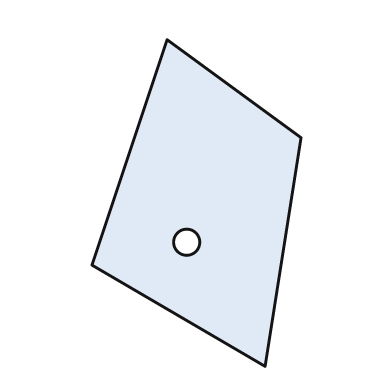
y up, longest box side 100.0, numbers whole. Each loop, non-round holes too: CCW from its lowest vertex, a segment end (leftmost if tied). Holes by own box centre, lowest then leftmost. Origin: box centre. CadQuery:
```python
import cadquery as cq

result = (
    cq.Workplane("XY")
    .moveTo(21.0, -50.0)
    .lineTo(32.0, 20.0)
    .lineTo(-9.0, 50.0)
    .lineTo(-32.0, -19.0)
    .close()
    .moveTo(-3.0, -12.0)
    .circle(4.0)
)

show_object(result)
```